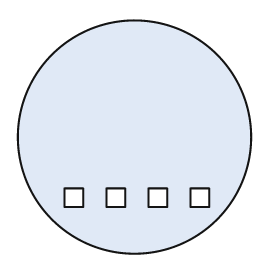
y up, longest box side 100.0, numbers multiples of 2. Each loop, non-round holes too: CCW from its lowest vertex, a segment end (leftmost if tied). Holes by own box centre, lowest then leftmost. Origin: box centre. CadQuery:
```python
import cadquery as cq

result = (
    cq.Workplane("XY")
    .moveTo(0.0, 0.0)
    .circle(50.0)
    .moveTo(-30.0, -30.0)
    .lineTo(-22.0, -30.0)
    .lineTo(-22.0, -22.0)
    .lineTo(-30.0, -22.0)
    .close()
    .moveTo(-12.0, -30.0)
    .lineTo(-4.0, -30.0)
    .lineTo(-4.0, -22.0)
    .lineTo(-12.0, -22.0)
    .close()
    .moveTo(6.0, -30.0)
    .lineTo(14.0, -30.0)
    .lineTo(14.0, -22.0)
    .lineTo(6.0, -22.0)
    .close()
    .moveTo(24.0, -30.0)
    .lineTo(32.0, -30.0)
    .lineTo(32.0, -22.0)
    .lineTo(24.0, -22.0)
    .close()
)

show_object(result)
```